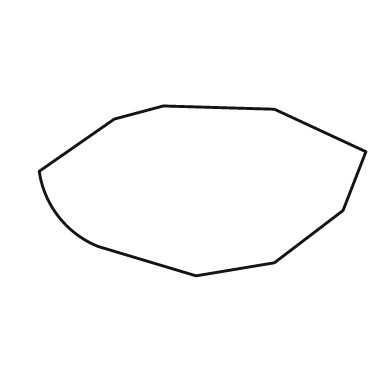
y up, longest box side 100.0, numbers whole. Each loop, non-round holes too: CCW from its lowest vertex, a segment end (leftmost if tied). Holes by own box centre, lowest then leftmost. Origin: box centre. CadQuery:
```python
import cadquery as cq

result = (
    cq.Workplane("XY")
    .moveTo(-2.0, -26.0)
    .lineTo(22.0, -22.0)
    .lineTo(43.0, -6.0)
    .lineTo(50.0, 12.0)
    .lineTo(22.0, 25.0)
    .lineTo(-12.0, 26.0)
    .lineTo(-27.0, 22.0)
    .lineTo(-50.0, 6.0)
    .threePointArc((-44.0, -8.0), (-32.0, -17.0))
    .close()
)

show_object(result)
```